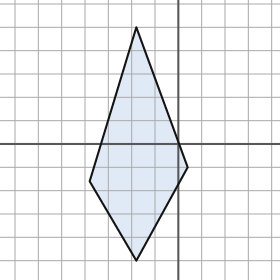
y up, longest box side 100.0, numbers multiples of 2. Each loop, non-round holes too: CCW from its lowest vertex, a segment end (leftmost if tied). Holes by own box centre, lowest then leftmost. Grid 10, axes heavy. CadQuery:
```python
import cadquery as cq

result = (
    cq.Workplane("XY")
    .moveTo(-18.0, -50.0)
    .lineTo(4.0, -10.0)
    .lineTo(-18.0, 50.0)
    .lineTo(-38.0, -16.0)
    .close()
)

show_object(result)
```